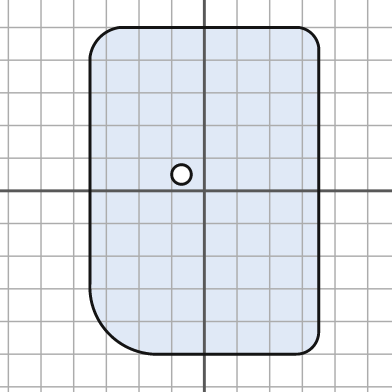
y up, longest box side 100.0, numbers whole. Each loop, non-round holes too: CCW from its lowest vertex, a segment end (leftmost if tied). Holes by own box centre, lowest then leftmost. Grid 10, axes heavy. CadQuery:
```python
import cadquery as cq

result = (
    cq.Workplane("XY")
    .moveTo(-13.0, -50.0)
    .lineTo(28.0, -50.0)
    .threePointArc((33.0, -48.0), (35.0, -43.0))
    .lineTo(35.0, 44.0)
    .threePointArc((33.0, 48.0), (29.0, 50.0))
    .lineTo(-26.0, 50.0)
    .threePointArc((-32.0, 47.0), (-35.0, 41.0))
    .lineTo(-35.0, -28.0)
    .threePointArc((-29.0, -44.0), (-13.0, -50.0))
    .close()
    .moveTo(-7.0, 5.0)
    .circle(3.0)
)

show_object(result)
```